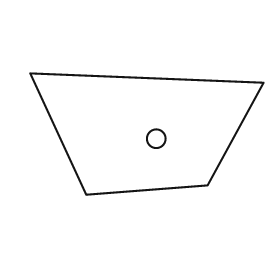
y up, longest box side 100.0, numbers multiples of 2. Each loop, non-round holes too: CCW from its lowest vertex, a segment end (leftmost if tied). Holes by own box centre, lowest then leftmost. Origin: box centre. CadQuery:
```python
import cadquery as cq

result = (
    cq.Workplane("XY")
    .moveTo(-26.0, -26.0)
    .lineTo(26.0, -22.0)
    .lineTo(50.0, 22.0)
    .lineTo(-50.0, 26.0)
    .close()
    .moveTo(4.0, -2.0)
    .circle(4.0)
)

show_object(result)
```